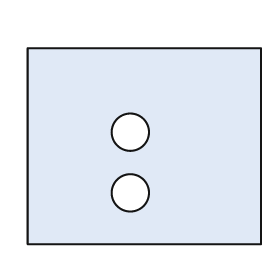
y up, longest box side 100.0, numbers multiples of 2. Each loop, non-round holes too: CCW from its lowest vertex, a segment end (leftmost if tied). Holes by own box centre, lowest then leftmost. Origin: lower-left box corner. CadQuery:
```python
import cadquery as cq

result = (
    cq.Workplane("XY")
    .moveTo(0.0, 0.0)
    .lineTo(100.0, 0.0)
    .lineTo(100.0, 84.0)
    .lineTo(0.0, 84.0)
    .close()
    .moveTo(44.0, 22.0)
    .circle(8.0)
    .moveTo(44.0, 48.0)
    .circle(8.0)
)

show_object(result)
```